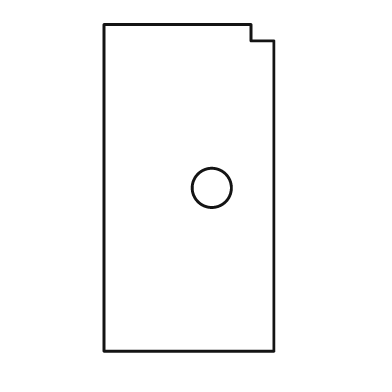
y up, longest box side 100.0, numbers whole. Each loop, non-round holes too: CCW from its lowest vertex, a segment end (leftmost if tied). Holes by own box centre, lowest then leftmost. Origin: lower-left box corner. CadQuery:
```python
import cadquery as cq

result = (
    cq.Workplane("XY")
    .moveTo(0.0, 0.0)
    .lineTo(52.0, 0.0)
    .lineTo(52.0, 95.0)
    .lineTo(45.0, 95.0)
    .lineTo(45.0, 100.0)
    .lineTo(0.0, 100.0)
    .close()
    .moveTo(33.0, 50.0)
    .circle(6.0)
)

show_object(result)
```